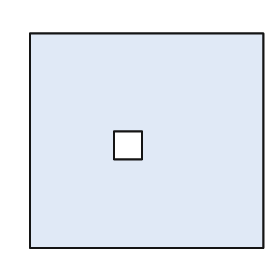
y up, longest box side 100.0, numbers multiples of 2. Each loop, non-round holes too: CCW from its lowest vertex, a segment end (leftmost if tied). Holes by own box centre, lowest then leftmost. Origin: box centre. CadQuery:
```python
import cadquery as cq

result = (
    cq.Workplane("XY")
    .moveTo(-50.0, -46.0)
    .lineTo(50.0, -46.0)
    .lineTo(50.0, 46.0)
    .lineTo(-50.0, 46.0)
    .close()
    .moveTo(-14.0, -8.0)
    .lineTo(-2.0, -8.0)
    .lineTo(-2.0, 4.0)
    .lineTo(-14.0, 4.0)
    .close()
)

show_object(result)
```